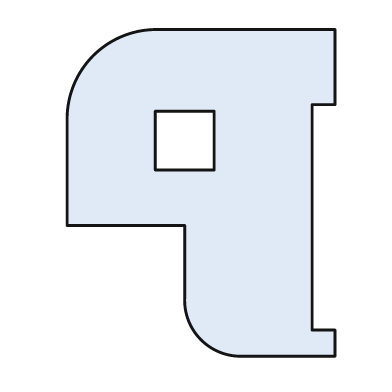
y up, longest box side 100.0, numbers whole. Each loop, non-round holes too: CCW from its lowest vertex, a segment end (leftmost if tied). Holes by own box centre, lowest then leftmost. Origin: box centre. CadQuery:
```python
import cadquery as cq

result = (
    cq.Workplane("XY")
    .moveTo(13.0, -50.0)
    .lineTo(41.0, -50.0)
    .lineTo(41.0, -42.0)
    .lineTo(34.0, -42.0)
    .lineTo(34.0, 27.0)
    .lineTo(41.0, 27.0)
    .lineTo(41.0, 50.0)
    .lineTo(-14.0, 50.0)
    .threePointArc((-33.0, 42.0), (-41.0, 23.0))
    .lineTo(-41.0, -10.0)
    .lineTo(-5.0, -10.0)
    .lineTo(-5.0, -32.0)
    .threePointArc((0.0, -45.0), (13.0, -50.0))
    .close()
    .moveTo(-14.0, 7.0)
    .lineTo(4.0, 7.0)
    .lineTo(4.0, 25.0)
    .lineTo(-14.0, 25.0)
    .close()
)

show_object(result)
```